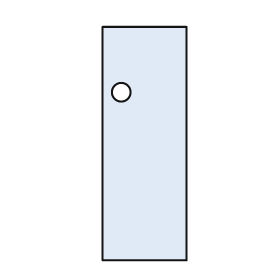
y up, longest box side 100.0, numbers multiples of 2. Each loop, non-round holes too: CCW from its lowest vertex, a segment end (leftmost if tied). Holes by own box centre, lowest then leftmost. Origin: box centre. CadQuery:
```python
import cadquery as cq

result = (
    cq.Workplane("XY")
    .moveTo(-18.0, -50.0)
    .lineTo(18.0, -50.0)
    .lineTo(18.0, 50.0)
    .lineTo(-18.0, 50.0)
    .close()
    .moveTo(-10.0, 22.0)
    .circle(4.0)
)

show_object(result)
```